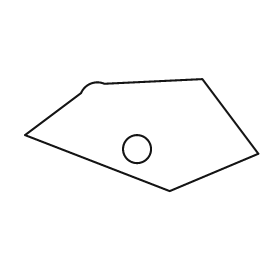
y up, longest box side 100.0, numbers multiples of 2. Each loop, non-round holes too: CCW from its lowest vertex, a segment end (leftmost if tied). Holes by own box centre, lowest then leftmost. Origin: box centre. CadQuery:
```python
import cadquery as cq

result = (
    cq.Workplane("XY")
    .moveTo(12.0, -24.0)
    .lineTo(50.0, -8.0)
    .lineTo(26.0, 24.0)
    .lineTo(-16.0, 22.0)
    .threePointArc((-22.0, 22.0), (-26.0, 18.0))
    .lineTo(-50.0, 0.0)
    .close()
    .moveTo(-2.0, -6.0)
    .circle(6.0)
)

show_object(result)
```